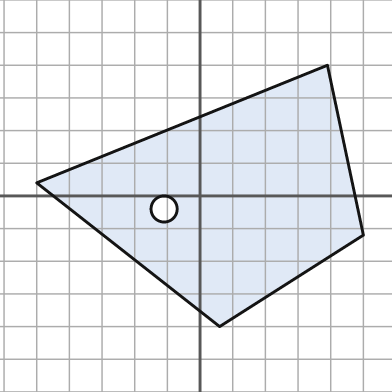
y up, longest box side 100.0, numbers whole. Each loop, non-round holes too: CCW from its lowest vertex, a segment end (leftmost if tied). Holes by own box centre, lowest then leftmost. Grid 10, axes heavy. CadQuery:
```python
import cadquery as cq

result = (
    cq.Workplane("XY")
    .moveTo(6.0, -40.0)
    .lineTo(50.0, -12.0)
    .lineTo(39.0, 40.0)
    .lineTo(-50.0, 4.0)
    .close()
    .moveTo(-11.0, -4.0)
    .circle(4.0)
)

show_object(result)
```